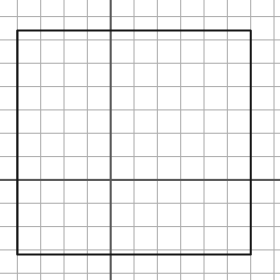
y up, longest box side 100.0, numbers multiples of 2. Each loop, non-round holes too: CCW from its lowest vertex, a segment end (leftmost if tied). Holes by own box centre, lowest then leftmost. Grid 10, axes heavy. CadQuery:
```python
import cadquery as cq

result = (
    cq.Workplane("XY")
    .moveTo(-40.0, -32.0)
    .lineTo(60.0, -32.0)
    .lineTo(60.0, 64.0)
    .lineTo(-40.0, 64.0)
    .close()
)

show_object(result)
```